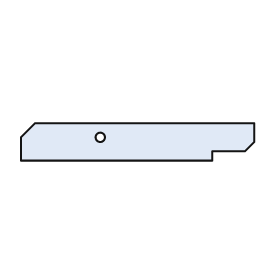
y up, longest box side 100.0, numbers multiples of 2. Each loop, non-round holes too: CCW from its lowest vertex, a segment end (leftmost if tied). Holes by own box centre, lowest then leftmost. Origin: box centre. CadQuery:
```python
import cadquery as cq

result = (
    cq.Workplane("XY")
    .moveTo(-50.0, -8.0)
    .lineTo(32.0, -8.0)
    .lineTo(32.0, -4.0)
    .lineTo(46.0, -4.0)
    .lineTo(50.0, 0.0)
    .lineTo(50.0, 8.0)
    .lineTo(-44.0, 8.0)
    .lineTo(-50.0, 2.0)
    .close()
    .moveTo(-16.0, 2.0)
    .circle(2.0)
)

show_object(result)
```